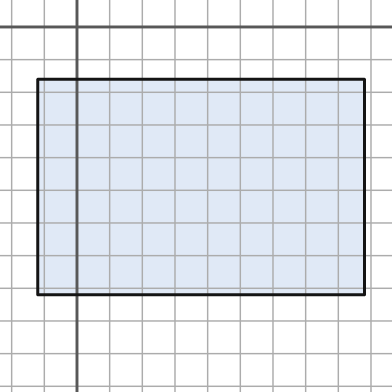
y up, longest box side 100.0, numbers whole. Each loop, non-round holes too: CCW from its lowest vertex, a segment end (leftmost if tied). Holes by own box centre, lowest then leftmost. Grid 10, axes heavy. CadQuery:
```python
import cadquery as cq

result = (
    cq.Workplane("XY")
    .moveTo(-12.0, -82.0)
    .lineTo(88.0, -82.0)
    .lineTo(88.0, -16.0)
    .lineTo(-12.0, -16.0)
    .close()
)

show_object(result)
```